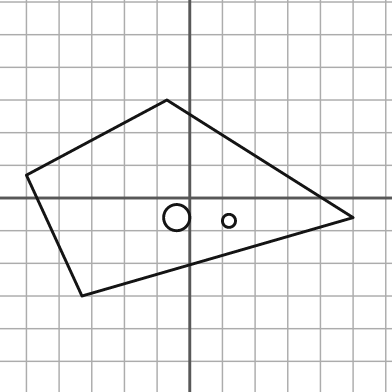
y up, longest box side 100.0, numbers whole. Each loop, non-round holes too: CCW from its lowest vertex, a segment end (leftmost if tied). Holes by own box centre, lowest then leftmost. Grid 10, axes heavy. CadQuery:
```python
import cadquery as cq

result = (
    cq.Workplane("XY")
    .moveTo(-33.0, -30.0)
    .lineTo(50.0, -6.0)
    .lineTo(-7.0, 30.0)
    .lineTo(-50.0, 7.0)
    .close()
    .moveTo(12.0, -7.0)
    .circle(2.0)
    .moveTo(-4.0, -6.0)
    .circle(4.0)
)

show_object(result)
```